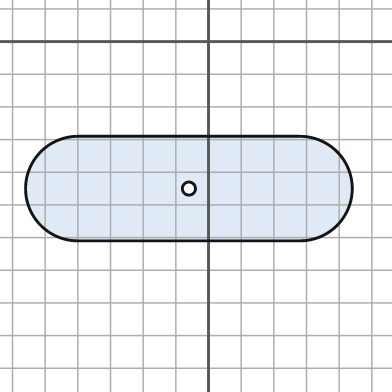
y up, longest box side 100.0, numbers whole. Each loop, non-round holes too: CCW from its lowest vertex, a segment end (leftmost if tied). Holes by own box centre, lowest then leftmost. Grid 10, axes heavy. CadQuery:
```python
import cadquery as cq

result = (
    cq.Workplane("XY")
    .moveTo(-40.0, -61.0)
    .lineTo(28.0, -61.0)
    .threePointArc((44.0, -45.0), (28.0, -29.0))
    .lineTo(-40.0, -29.0)
    .threePointArc((-56.0, -45.0), (-40.0, -61.0))
    .close()
    .moveTo(-6.0, -45.0)
    .circle(2.0)
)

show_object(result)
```